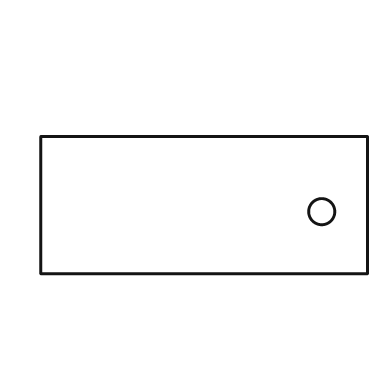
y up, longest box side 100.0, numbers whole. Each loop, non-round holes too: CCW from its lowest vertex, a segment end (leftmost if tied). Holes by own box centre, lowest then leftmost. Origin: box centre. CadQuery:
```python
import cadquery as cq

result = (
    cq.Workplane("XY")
    .moveTo(-50.0, -21.0)
    .lineTo(50.0, -21.0)
    .lineTo(50.0, 21.0)
    .lineTo(-50.0, 21.0)
    .close()
    .moveTo(36.0, -2.0)
    .circle(4.0)
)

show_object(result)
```